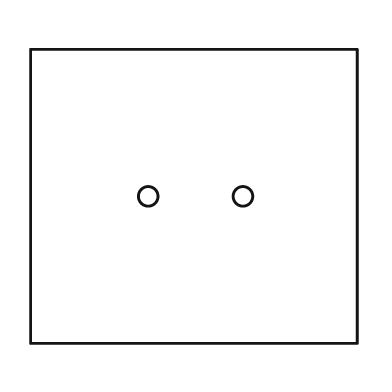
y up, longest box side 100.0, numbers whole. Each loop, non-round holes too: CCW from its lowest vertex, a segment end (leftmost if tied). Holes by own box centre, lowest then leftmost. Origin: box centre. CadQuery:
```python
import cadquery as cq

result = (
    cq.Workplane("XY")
    .moveTo(-50.0, -45.0)
    .lineTo(50.0, -45.0)
    .lineTo(50.0, 45.0)
    .lineTo(-50.0, 45.0)
    .close()
    .moveTo(-14.0, 0.0)
    .circle(3.0)
    .moveTo(15.0, 0.0)
    .circle(3.0)
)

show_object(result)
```